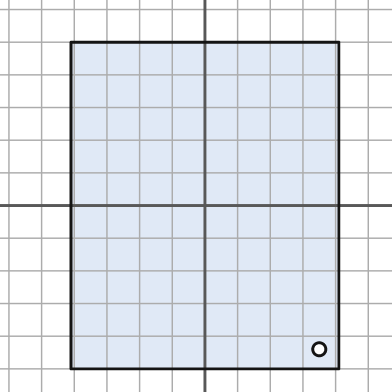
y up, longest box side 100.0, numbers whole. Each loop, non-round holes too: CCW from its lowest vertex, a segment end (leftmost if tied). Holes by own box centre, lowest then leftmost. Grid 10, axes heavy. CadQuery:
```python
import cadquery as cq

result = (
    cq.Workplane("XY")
    .moveTo(-41.0, -50.0)
    .lineTo(41.0, -50.0)
    .lineTo(41.0, 50.0)
    .lineTo(-41.0, 50.0)
    .close()
    .moveTo(35.0, -44.0)
    .circle(2.0)
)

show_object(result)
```